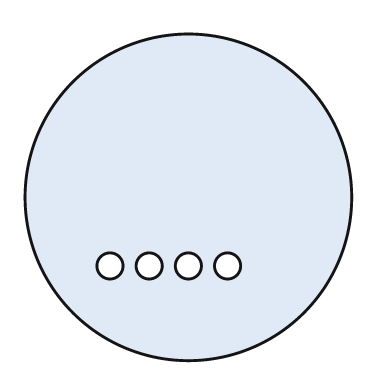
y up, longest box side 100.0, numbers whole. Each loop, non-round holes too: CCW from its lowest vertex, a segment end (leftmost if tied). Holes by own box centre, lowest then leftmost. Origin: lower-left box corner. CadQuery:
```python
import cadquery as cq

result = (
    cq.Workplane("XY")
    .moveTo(50.0, 50.0)
    .circle(50.0)
    .moveTo(26.0, 29.0)
    .circle(4.0)
    .moveTo(38.0, 29.0)
    .circle(4.0)
    .moveTo(50.0, 29.0)
    .circle(4.0)
    .moveTo(62.0, 29.0)
    .circle(4.0)
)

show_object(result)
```